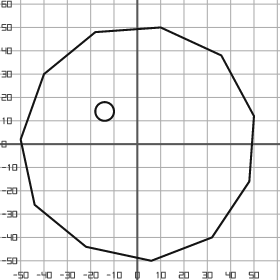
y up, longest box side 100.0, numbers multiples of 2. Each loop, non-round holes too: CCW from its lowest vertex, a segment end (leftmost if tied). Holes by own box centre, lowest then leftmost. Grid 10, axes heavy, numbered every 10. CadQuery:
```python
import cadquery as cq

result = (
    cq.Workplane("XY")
    .moveTo(6.0, -50.0)
    .lineTo(32.0, -40.0)
    .lineTo(48.0, -16.0)
    .lineTo(50.0, 12.0)
    .lineTo(36.0, 38.0)
    .lineTo(10.0, 50.0)
    .lineTo(-18.0, 48.0)
    .lineTo(-40.0, 30.0)
    .lineTo(-50.0, 2.0)
    .lineTo(-44.0, -26.0)
    .lineTo(-22.0, -44.0)
    .close()
    .moveTo(-14.0, 14.0)
    .circle(4.0)
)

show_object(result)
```